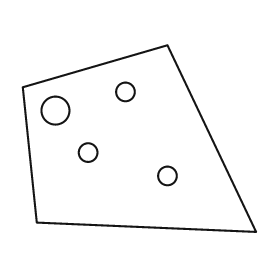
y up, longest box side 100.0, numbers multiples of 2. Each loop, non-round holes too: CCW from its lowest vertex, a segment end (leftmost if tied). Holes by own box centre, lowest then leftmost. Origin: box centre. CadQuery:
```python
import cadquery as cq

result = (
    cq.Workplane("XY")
    .moveTo(50.0, -40.0)
    .lineTo(12.0, 40.0)
    .lineTo(-50.0, 22.0)
    .lineTo(-44.0, -36.0)
    .close()
    .moveTo(12.0, -16.0)
    .circle(4.0)
    .moveTo(-22.0, -6.0)
    .circle(4.0)
    .moveTo(-36.0, 12.0)
    .circle(6.0)
    .moveTo(-6.0, 20.0)
    .circle(4.0)
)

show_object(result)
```